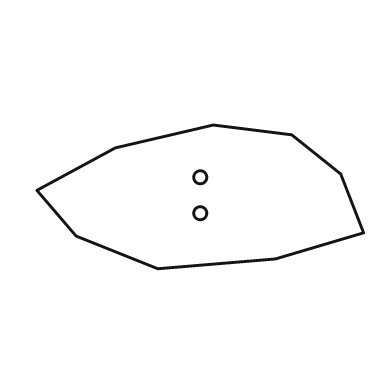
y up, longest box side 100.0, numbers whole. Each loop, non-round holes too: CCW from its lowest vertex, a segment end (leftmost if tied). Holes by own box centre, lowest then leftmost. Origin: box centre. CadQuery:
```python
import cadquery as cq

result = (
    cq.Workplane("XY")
    .moveTo(-13.0, -22.0)
    .lineTo(23.0, -19.0)
    .lineTo(50.0, -11.0)
    .lineTo(43.0, 7.0)
    .lineTo(28.0, 19.0)
    .lineTo(4.0, 22.0)
    .lineTo(-26.0, 15.0)
    .lineTo(-50.0, 2.0)
    .lineTo(-38.0, -12.0)
    .close()
    .moveTo(0.0, -5.0)
    .circle(2.0)
    .moveTo(0.0, 6.0)
    .circle(2.0)
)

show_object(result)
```